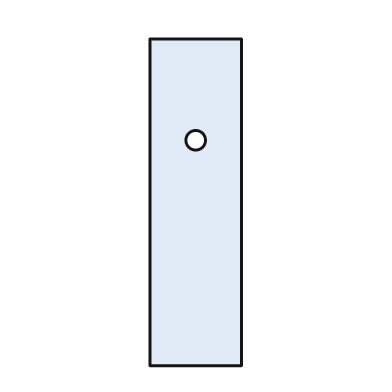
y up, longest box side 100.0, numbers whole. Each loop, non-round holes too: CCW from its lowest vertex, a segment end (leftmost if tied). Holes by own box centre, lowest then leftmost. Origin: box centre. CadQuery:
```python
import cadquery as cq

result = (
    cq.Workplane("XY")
    .moveTo(-14.0, -50.0)
    .lineTo(14.0, -50.0)
    .lineTo(14.0, 50.0)
    .lineTo(-14.0, 50.0)
    .close()
    .moveTo(0.0, 19.0)
    .circle(3.0)
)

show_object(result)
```